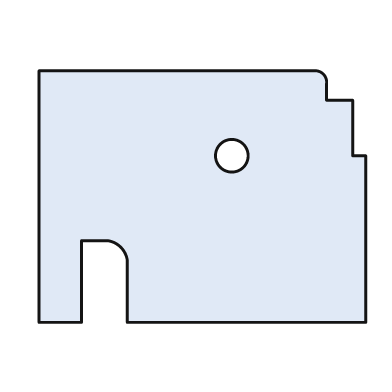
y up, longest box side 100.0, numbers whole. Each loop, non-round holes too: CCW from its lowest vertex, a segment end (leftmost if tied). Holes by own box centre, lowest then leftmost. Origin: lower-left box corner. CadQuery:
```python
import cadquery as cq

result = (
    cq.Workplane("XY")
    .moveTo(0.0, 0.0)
    .lineTo(13.0, 0.0)
    .lineTo(13.0, 25.0)
    .lineTo(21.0, 25.0)
    .threePointArc((25.0, 23.0), (27.0, 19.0))
    .lineTo(27.0, 0.0)
    .lineTo(100.0, 0.0)
    .lineTo(100.0, 51.0)
    .lineTo(96.0, 51.0)
    .lineTo(96.0, 68.0)
    .lineTo(88.0, 68.0)
    .lineTo(88.0, 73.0)
    .threePointArc((87.0, 76.0), (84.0, 77.0))
    .lineTo(0.0, 77.0)
    .close()
    .moveTo(59.0, 51.0)
    .circle(5.0)
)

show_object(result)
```